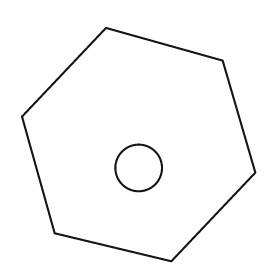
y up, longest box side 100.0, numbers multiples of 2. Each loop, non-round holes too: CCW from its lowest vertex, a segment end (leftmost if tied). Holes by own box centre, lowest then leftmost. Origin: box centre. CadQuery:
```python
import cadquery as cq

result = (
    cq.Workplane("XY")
    .moveTo(14.0, -50.0)
    .lineTo(50.0, -12.0)
    .lineTo(36.0, 36.0)
    .lineTo(-14.0, 50.0)
    .lineTo(-50.0, 12.0)
    .lineTo(-36.0, -38.0)
    .close()
    .moveTo(0.0, -10.0)
    .circle(10.0)
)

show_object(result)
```